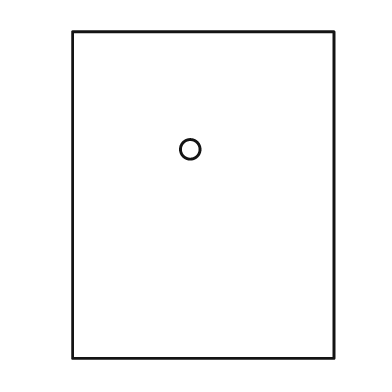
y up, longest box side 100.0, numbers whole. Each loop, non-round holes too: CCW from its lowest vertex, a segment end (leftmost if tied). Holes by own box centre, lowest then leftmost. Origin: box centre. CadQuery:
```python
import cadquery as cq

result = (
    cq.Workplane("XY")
    .moveTo(-40.0, -50.0)
    .lineTo(40.0, -50.0)
    .lineTo(40.0, 50.0)
    .lineTo(-40.0, 50.0)
    .close()
    .moveTo(-4.0, 14.0)
    .circle(3.0)
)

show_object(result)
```